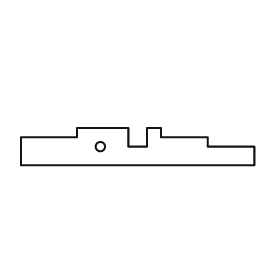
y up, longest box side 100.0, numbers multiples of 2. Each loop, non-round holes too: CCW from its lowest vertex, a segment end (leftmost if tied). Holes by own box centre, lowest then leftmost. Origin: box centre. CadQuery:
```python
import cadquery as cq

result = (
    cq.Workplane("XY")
    .moveTo(-50.0, -8.0)
    .lineTo(50.0, -8.0)
    .lineTo(50.0, 0.0)
    .lineTo(30.0, 0.0)
    .lineTo(30.0, 4.0)
    .lineTo(10.0, 4.0)
    .lineTo(10.0, 8.0)
    .lineTo(4.0, 8.0)
    .lineTo(4.0, 0.0)
    .lineTo(-4.0, 0.0)
    .lineTo(-4.0, 8.0)
    .lineTo(-26.0, 8.0)
    .lineTo(-26.0, 4.0)
    .lineTo(-50.0, 4.0)
    .close()
    .moveTo(-16.0, 0.0)
    .circle(2.0)
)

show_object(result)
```